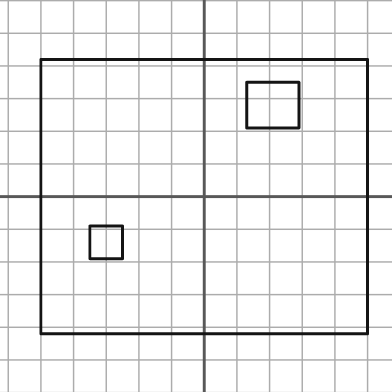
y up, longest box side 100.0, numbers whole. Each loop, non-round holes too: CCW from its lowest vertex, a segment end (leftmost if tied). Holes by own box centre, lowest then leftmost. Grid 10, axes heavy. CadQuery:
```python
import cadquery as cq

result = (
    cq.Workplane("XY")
    .moveTo(-50.0, -42.0)
    .lineTo(50.0, -42.0)
    .lineTo(50.0, 42.0)
    .lineTo(-50.0, 42.0)
    .close()
    .moveTo(-35.0, -19.0)
    .lineTo(-25.0, -19.0)
    .lineTo(-25.0, -9.0)
    .lineTo(-35.0, -9.0)
    .close()
    .moveTo(13.0, 21.0)
    .lineTo(29.0, 21.0)
    .lineTo(29.0, 35.0)
    .lineTo(13.0, 35.0)
    .close()
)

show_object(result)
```